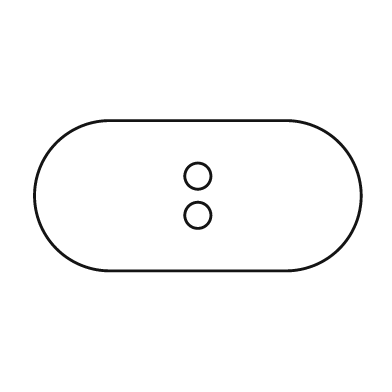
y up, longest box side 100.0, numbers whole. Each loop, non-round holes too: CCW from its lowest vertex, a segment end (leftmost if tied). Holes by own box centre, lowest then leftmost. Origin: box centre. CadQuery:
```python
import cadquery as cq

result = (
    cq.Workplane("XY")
    .moveTo(-27.0, -23.0)
    .lineTo(27.0, -23.0)
    .threePointArc((50.0, 0.0), (27.0, 23.0))
    .lineTo(-27.0, 23.0)
    .threePointArc((-50.0, 0.0), (-27.0, -23.0))
    .close()
    .moveTo(0.0, -6.0)
    .circle(4.0)
    .moveTo(0.0, 6.0)
    .circle(4.0)
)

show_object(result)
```